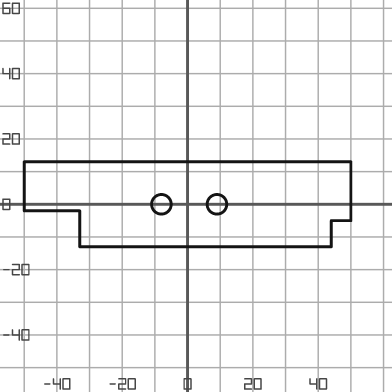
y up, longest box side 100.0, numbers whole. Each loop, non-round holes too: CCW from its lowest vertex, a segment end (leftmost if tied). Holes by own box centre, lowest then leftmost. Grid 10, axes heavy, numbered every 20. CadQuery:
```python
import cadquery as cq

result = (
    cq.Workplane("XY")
    .moveTo(-33.0, -13.0)
    .lineTo(44.0, -13.0)
    .lineTo(44.0, -5.0)
    .lineTo(50.0, -5.0)
    .lineTo(50.0, 13.0)
    .lineTo(-50.0, 13.0)
    .lineTo(-50.0, -2.0)
    .lineTo(-33.0, -2.0)
    .close()
    .moveTo(-8.0, 0.0)
    .circle(3.0)
    .moveTo(9.0, 0.0)
    .circle(3.0)
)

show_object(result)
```